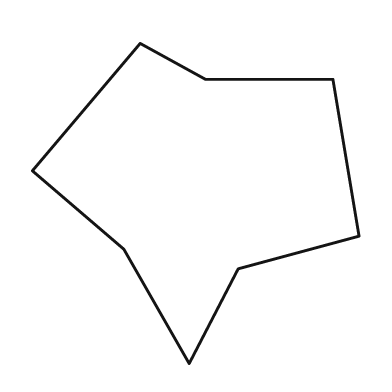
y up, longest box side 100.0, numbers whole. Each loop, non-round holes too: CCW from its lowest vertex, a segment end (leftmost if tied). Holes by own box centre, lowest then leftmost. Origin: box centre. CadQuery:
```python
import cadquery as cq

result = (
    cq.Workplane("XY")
    .moveTo(-2.0, -49.0)
    .lineTo(13.0, -20.0)
    .lineTo(50.0, -10.0)
    .lineTo(42.0, 38.0)
    .lineTo(3.0, 38.0)
    .lineTo(-17.0, 49.0)
    .lineTo(-50.0, 10.0)
    .lineTo(-22.0, -14.0)
    .close()
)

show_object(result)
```